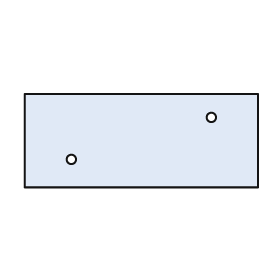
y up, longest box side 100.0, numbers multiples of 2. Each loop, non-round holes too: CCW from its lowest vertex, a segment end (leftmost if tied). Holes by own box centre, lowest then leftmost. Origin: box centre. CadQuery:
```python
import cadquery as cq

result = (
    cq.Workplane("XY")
    .moveTo(-50.0, -20.0)
    .lineTo(50.0, -20.0)
    .lineTo(50.0, 20.0)
    .lineTo(-50.0, 20.0)
    .close()
    .moveTo(-30.0, -8.0)
    .circle(2.0)
    .moveTo(30.0, 10.0)
    .circle(2.0)
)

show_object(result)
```